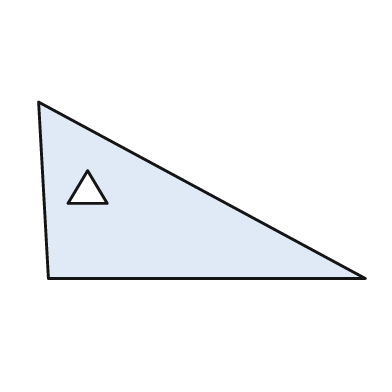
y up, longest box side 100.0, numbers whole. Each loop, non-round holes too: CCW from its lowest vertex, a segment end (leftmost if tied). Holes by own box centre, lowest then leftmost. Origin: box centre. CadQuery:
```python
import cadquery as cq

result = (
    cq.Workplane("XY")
    .moveTo(-47.0, -27.0)
    .lineTo(50.0, -27.0)
    .lineTo(-50.0, 27.0)
    .close()
    .moveTo(-41.0, -4.0)
    .lineTo(-29.0, -4.0)
    .lineTo(-35.0, 6.0)
    .close()
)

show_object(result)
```